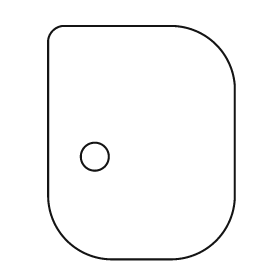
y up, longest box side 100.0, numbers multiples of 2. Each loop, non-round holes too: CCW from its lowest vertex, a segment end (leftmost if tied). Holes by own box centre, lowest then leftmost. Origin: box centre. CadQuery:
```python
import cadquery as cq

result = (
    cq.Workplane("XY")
    .moveTo(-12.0, -50.0)
    .lineTo(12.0, -50.0)
    .threePointArc((32.0, -42.0), (40.0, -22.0))
    .lineTo(40.0, 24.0)
    .threePointArc((32.0, 42.0), (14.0, 50.0))
    .lineTo(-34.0, 50.0)
    .threePointArc((-38.0, 48.0), (-40.0, 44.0))
    .lineTo(-40.0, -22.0)
    .threePointArc((-32.0, -42.0), (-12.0, -50.0))
    .close()
    .moveTo(-20.0, -6.0)
    .circle(6.0)
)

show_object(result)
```